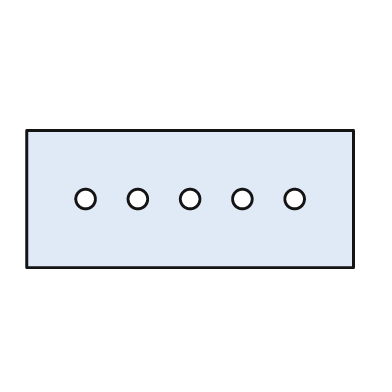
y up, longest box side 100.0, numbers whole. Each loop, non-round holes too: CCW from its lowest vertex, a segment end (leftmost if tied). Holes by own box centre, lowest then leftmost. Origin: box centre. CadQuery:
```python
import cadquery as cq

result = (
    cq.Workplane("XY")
    .moveTo(-50.0, -21.0)
    .lineTo(50.0, -21.0)
    .lineTo(50.0, 21.0)
    .lineTo(-50.0, 21.0)
    .close()
    .moveTo(-32.0, 0.0)
    .circle(3.0)
    .moveTo(-16.0, 0.0)
    .circle(3.0)
    .moveTo(0.0, 0.0)
    .circle(3.0)
    .moveTo(16.0, 0.0)
    .circle(3.0)
    .moveTo(32.0, 0.0)
    .circle(3.0)
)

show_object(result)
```